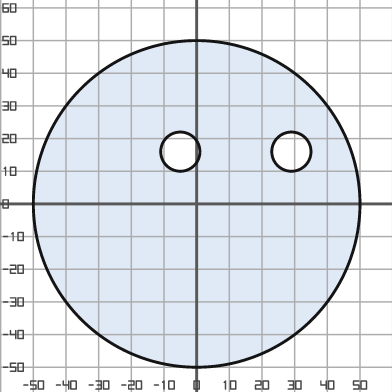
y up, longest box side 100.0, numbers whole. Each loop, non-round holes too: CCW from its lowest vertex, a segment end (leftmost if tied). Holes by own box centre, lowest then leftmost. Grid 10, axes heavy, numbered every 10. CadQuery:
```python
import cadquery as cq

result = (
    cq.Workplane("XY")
    .moveTo(0.0, 0.0)
    .circle(50.0)
    .moveTo(-5.0, 16.0)
    .circle(6.0)
    .moveTo(29.0, 16.0)
    .circle(6.0)
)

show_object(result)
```